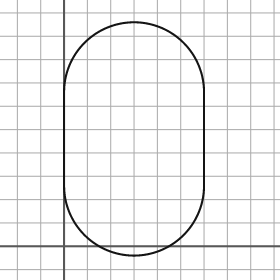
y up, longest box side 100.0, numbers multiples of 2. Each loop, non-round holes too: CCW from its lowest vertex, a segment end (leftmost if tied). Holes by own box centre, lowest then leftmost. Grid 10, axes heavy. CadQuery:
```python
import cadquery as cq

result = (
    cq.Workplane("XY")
    .moveTo(0.0, 26.0)
    .threePointArc((30.0, -4.0), (60.0, 26.0))
    .lineTo(60.0, 66.0)
    .threePointArc((30.0, 96.0), (0.0, 66.0))
    .close()
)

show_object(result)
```